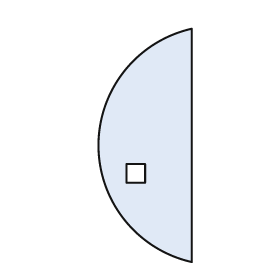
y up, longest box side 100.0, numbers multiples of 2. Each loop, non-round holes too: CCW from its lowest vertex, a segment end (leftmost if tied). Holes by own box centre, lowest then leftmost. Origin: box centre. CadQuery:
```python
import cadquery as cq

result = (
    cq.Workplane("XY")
    .moveTo(20.0, -50.0)
    .lineTo(20.0, 50.0)
    .threePointArc((-20.0, 0.0), (20.0, -50.0))
    .close()
    .moveTo(-8.0, -16.0)
    .lineTo(0.0, -16.0)
    .lineTo(0.0, -8.0)
    .lineTo(-8.0, -8.0)
    .close()
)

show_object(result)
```